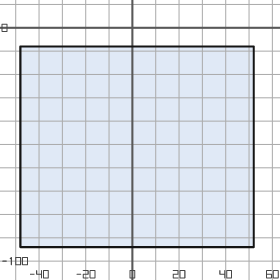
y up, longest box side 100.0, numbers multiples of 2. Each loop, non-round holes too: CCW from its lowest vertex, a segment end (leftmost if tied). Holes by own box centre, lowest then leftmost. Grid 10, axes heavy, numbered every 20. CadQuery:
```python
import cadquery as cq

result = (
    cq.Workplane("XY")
    .moveTo(-48.0, -94.0)
    .lineTo(52.0, -94.0)
    .lineTo(52.0, -8.0)
    .lineTo(-48.0, -8.0)
    .close()
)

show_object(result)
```